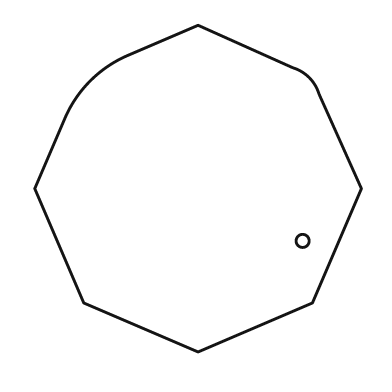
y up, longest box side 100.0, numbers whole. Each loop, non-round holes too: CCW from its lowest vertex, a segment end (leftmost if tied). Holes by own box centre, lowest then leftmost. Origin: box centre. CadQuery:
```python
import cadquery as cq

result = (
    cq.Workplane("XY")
    .moveTo(0.0, -50.0)
    .lineTo(35.0, -35.0)
    .lineTo(50.0, 0.0)
    .lineTo(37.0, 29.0)
    .threePointArc((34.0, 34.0), (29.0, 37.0))
    .lineTo(0.0, 50.0)
    .lineTo(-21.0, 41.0)
    .threePointArc((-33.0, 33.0), (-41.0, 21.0))
    .lineTo(-50.0, 0.0)
    .lineTo(-35.0, -35.0)
    .close()
    .moveTo(32.0, -16.0)
    .circle(2.0)
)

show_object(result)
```